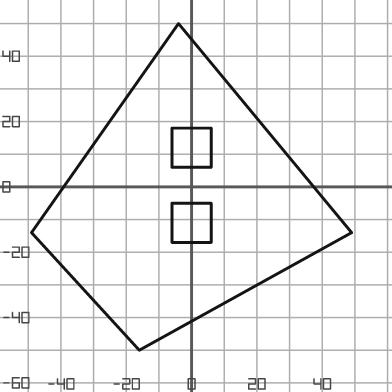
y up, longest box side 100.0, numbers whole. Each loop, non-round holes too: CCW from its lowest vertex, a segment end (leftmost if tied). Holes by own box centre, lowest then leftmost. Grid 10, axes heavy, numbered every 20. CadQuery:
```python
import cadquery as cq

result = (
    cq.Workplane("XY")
    .moveTo(-16.0, -50.0)
    .lineTo(49.0, -14.0)
    .lineTo(-4.0, 50.0)
    .lineTo(-49.0, -14.0)
    .close()
    .moveTo(-6.0, -17.0)
    .lineTo(6.0, -17.0)
    .lineTo(6.0, -5.0)
    .lineTo(-6.0, -5.0)
    .close()
    .moveTo(-6.0, 6.0)
    .lineTo(6.0, 6.0)
    .lineTo(6.0, 18.0)
    .lineTo(-6.0, 18.0)
    .close()
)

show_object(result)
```